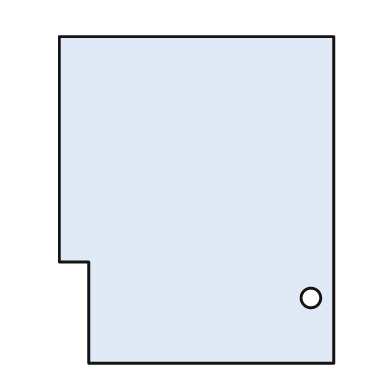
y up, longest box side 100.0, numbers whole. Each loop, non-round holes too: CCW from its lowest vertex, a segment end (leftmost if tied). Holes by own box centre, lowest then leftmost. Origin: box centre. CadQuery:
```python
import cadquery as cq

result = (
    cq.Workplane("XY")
    .moveTo(-33.0, -50.0)
    .lineTo(42.0, -50.0)
    .lineTo(42.0, 50.0)
    .lineTo(-42.0, 50.0)
    .lineTo(-42.0, -19.0)
    .lineTo(-33.0, -19.0)
    .close()
    .moveTo(35.0, -30.0)
    .circle(3.0)
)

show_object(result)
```